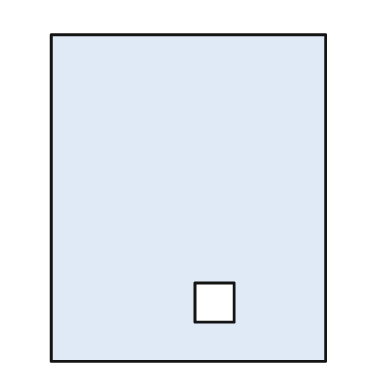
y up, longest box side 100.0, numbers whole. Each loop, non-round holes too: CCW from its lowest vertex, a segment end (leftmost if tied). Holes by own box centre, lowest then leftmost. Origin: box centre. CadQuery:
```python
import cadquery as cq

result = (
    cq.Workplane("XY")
    .moveTo(-42.0, -50.0)
    .lineTo(42.0, -50.0)
    .lineTo(42.0, 50.0)
    .lineTo(-42.0, 50.0)
    .close()
    .moveTo(2.0, -38.0)
    .lineTo(14.0, -38.0)
    .lineTo(14.0, -26.0)
    .lineTo(2.0, -26.0)
    .close()
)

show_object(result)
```